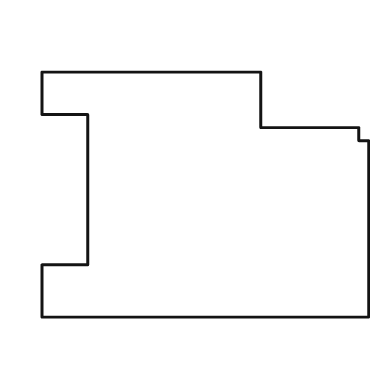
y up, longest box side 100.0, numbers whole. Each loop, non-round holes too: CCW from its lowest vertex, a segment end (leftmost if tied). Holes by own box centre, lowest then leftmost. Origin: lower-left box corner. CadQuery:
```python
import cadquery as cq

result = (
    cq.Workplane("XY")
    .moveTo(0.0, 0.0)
    .lineTo(100.0, 0.0)
    .lineTo(100.0, 54.0)
    .lineTo(97.0, 54.0)
    .lineTo(97.0, 58.0)
    .lineTo(67.0, 58.0)
    .lineTo(67.0, 75.0)
    .lineTo(0.0, 75.0)
    .lineTo(0.0, 62.0)
    .lineTo(14.0, 62.0)
    .lineTo(14.0, 16.0)
    .lineTo(0.0, 16.0)
    .close()
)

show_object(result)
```